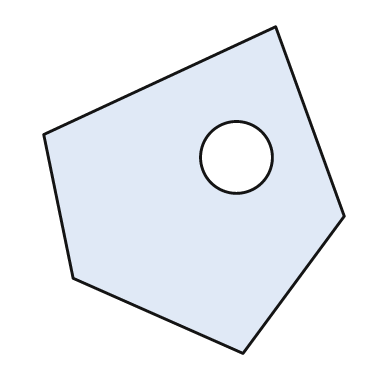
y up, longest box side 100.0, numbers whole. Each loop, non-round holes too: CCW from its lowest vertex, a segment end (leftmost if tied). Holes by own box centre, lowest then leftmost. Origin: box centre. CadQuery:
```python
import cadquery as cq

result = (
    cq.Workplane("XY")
    .moveTo(15.0, -50.0)
    .lineTo(46.0, -8.0)
    .lineTo(25.0, 50.0)
    .lineTo(-46.0, 17.0)
    .lineTo(-37.0, -27.0)
    .close()
    .moveTo(13.0, 10.0)
    .circle(11.0)
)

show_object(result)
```